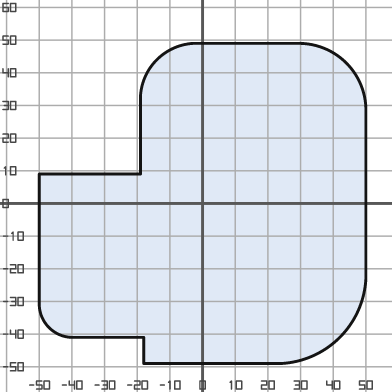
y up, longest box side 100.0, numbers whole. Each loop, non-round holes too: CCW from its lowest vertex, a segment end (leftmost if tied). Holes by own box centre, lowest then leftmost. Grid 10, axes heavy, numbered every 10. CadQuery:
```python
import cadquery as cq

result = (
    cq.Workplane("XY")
    .moveTo(-18.0, -49.0)
    .lineTo(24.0, -49.0)
    .threePointArc((42.0, -41.0), (50.0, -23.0))
    .lineTo(50.0, 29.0)
    .threePointArc((44.0, 43.0), (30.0, 49.0))
    .lineTo(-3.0, 49.0)
    .threePointArc((-14.0, 44.0), (-19.0, 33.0))
    .lineTo(-19.0, 9.0)
    .lineTo(-50.0, 9.0)
    .lineTo(-50.0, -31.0)
    .threePointArc((-47.0, -38.0), (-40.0, -41.0))
    .lineTo(-18.0, -41.0)
    .close()
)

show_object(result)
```